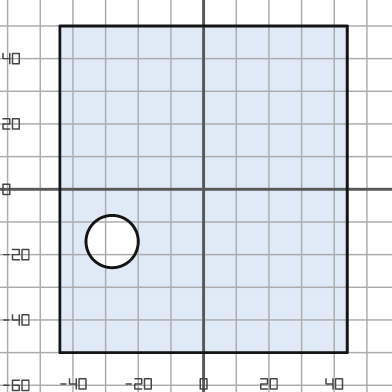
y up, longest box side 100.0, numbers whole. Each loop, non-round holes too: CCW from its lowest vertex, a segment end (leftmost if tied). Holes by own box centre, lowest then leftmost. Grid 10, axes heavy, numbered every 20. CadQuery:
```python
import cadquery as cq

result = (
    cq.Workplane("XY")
    .moveTo(-44.0, -50.0)
    .lineTo(44.0, -50.0)
    .lineTo(44.0, 50.0)
    .lineTo(-44.0, 50.0)
    .close()
    .moveTo(-28.0, -16.0)
    .circle(8.0)
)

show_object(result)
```